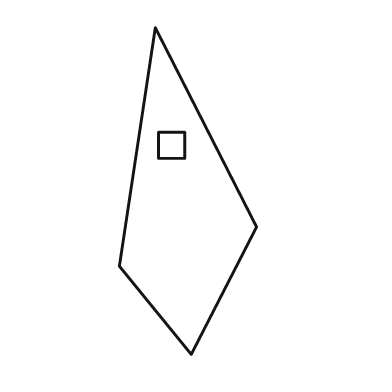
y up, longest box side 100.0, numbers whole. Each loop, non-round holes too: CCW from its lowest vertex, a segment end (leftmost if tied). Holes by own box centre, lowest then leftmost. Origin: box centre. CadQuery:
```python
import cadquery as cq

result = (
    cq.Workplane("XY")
    .moveTo(1.0, -50.0)
    .lineTo(21.0, -11.0)
    .lineTo(-10.0, 50.0)
    .lineTo(-21.0, -23.0)
    .close()
    .moveTo(-9.0, 10.0)
    .lineTo(-1.0, 10.0)
    .lineTo(-1.0, 18.0)
    .lineTo(-9.0, 18.0)
    .close()
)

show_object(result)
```